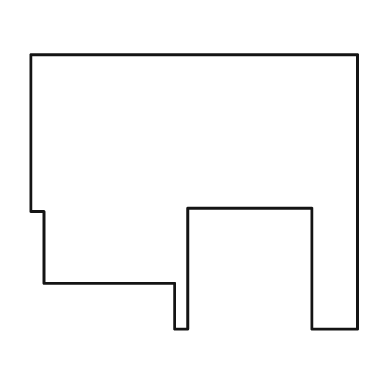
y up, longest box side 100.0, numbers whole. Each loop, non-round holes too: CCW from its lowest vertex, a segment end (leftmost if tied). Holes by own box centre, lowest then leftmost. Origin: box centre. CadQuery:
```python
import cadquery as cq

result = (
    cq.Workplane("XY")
    .moveTo(-6.0, -42.0)
    .lineTo(-2.0, -42.0)
    .lineTo(-2.0, -5.0)
    .lineTo(36.0, -5.0)
    .lineTo(36.0, -42.0)
    .lineTo(50.0, -42.0)
    .lineTo(50.0, 42.0)
    .lineTo(-50.0, 42.0)
    .lineTo(-50.0, -6.0)
    .lineTo(-46.0, -6.0)
    .lineTo(-46.0, -28.0)
    .lineTo(-6.0, -28.0)
    .close()
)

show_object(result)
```